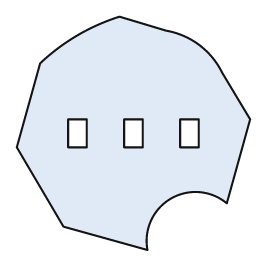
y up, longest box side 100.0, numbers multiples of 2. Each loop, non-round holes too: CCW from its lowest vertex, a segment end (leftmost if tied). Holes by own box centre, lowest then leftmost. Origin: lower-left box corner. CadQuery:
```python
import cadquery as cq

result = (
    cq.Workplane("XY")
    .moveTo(56.0, 0.0)
    .threePointArc((66.0, 22.0), (90.0, 20.0))
    .lineTo(100.0, 56.0)
    .lineTo(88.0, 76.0)
    .threePointArc((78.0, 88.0), (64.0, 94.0))
    .lineTo(44.0, 100.0)
    .threePointArc((26.0, 92.0), (10.0, 80.0))
    .lineTo(0.0, 44.0)
    .lineTo(20.0, 10.0)
    .close()
    .moveTo(22.0, 44.0)
    .lineTo(30.0, 44.0)
    .lineTo(30.0, 56.0)
    .lineTo(22.0, 56.0)
    .close()
    .moveTo(46.0, 44.0)
    .lineTo(54.0, 44.0)
    .lineTo(54.0, 56.0)
    .lineTo(46.0, 56.0)
    .close()
    .moveTo(70.0, 44.0)
    .lineTo(78.0, 44.0)
    .lineTo(78.0, 56.0)
    .lineTo(70.0, 56.0)
    .close()
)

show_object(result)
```